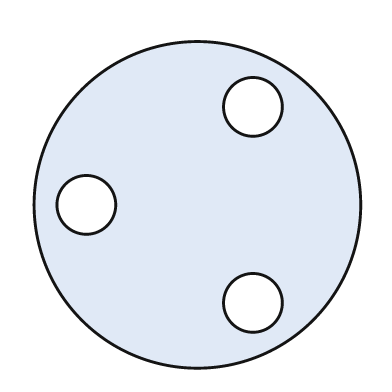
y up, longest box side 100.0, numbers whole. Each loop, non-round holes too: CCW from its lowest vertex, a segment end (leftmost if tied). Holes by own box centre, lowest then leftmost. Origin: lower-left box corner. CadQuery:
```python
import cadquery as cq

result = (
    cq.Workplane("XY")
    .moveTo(50.0, 50.0)
    .circle(50.0)
    .moveTo(67.0, 20.0)
    .circle(9.0)
    .moveTo(16.0, 50.0)
    .circle(9.0)
    .moveTo(67.0, 80.0)
    .circle(9.0)
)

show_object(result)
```